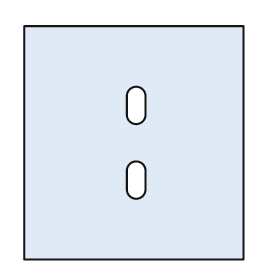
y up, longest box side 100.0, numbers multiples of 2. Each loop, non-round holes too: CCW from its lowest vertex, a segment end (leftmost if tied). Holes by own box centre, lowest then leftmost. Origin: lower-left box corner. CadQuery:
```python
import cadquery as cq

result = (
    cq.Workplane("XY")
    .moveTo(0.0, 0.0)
    .lineTo(94.0, 0.0)
    .lineTo(94.0, 100.0)
    .lineTo(0.0, 100.0)
    .close()
    .moveTo(44.0, 30.0)
    .threePointArc((48.0, 26.0), (52.0, 30.0))
    .lineTo(52.0, 38.0)
    .threePointArc((48.0, 42.0), (44.0, 38.0))
    .close()
    .moveTo(44.0, 62.0)
    .threePointArc((48.0, 58.0), (52.0, 62.0))
    .lineTo(52.0, 70.0)
    .threePointArc((48.0, 74.0), (44.0, 70.0))
    .close()
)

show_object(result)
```